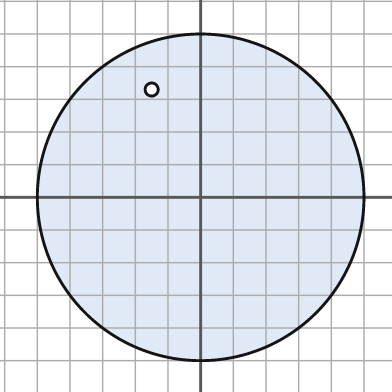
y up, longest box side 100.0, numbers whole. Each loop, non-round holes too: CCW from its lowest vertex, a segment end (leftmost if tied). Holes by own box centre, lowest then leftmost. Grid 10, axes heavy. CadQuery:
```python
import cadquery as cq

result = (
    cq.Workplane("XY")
    .moveTo(0.0, 0.0)
    .circle(50.0)
    .moveTo(-15.0, 33.0)
    .circle(2.0)
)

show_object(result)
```